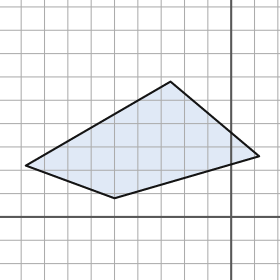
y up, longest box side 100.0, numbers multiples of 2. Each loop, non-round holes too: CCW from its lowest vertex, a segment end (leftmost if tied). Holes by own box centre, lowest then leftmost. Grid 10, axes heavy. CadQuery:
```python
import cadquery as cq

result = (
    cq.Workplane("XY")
    .moveTo(-50.0, 8.0)
    .lineTo(12.0, 26.0)
    .lineTo(-26.0, 58.0)
    .lineTo(-88.0, 22.0)
    .close()
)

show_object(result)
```